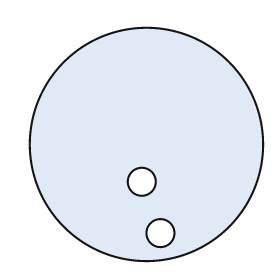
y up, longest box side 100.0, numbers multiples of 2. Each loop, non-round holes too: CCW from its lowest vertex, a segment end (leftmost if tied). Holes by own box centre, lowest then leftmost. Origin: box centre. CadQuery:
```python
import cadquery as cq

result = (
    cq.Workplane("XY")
    .moveTo(0.0, 0.0)
    .circle(50.0)
    .moveTo(6.0, -38.0)
    .circle(6.0)
    .moveTo(-2.0, -16.0)
    .circle(6.0)
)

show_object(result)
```